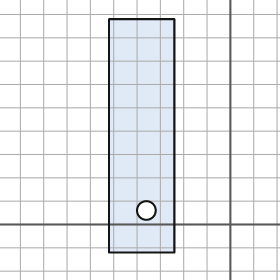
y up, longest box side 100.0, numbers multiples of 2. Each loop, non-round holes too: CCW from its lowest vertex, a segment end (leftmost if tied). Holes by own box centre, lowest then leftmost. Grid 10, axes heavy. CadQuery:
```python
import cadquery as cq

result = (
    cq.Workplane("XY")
    .moveTo(-52.0, -12.0)
    .lineTo(-24.0, -12.0)
    .lineTo(-24.0, 88.0)
    .lineTo(-52.0, 88.0)
    .close()
    .moveTo(-36.0, 6.0)
    .circle(4.0)
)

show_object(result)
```